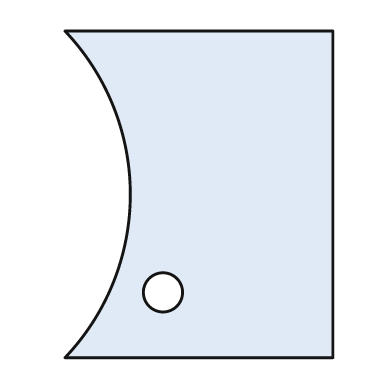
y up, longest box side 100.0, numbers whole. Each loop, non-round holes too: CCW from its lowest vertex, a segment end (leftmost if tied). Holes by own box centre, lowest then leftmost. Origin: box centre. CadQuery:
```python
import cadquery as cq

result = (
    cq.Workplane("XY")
    .moveTo(-41.0, -50.0)
    .lineTo(41.0, -50.0)
    .lineTo(41.0, 50.0)
    .lineTo(-41.0, 50.0)
    .threePointArc((-21.0, 0.0), (-41.0, -50.0))
    .close()
    .moveTo(-11.0, -30.0)
    .circle(6.0)
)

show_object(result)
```